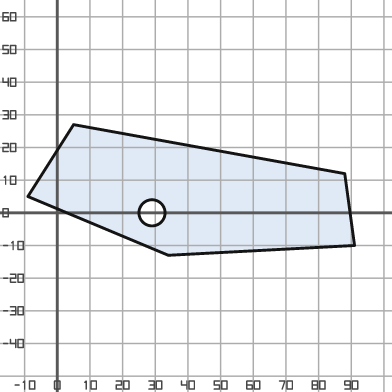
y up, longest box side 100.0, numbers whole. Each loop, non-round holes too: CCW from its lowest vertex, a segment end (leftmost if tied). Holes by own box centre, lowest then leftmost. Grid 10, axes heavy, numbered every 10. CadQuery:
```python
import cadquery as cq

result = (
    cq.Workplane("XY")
    .moveTo(34.0, -13.0)
    .lineTo(91.0, -10.0)
    .lineTo(88.0, 12.0)
    .lineTo(5.0, 27.0)
    .lineTo(-9.0, 5.0)
    .close()
    .moveTo(29.0, 0.0)
    .circle(4.0)
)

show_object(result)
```